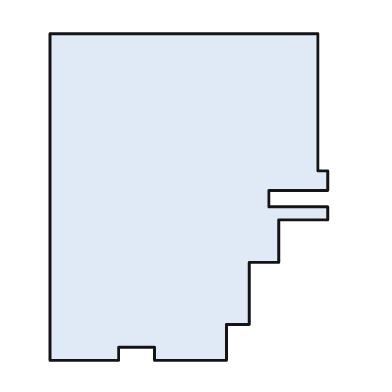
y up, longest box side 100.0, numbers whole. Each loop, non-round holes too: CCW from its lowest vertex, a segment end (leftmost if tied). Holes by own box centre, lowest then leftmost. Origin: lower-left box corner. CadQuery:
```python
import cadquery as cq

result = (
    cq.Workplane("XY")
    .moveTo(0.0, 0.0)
    .lineTo(21.0, 0.0)
    .lineTo(21.0, 4.0)
    .lineTo(32.0, 4.0)
    .lineTo(32.0, 0.0)
    .lineTo(54.0, 0.0)
    .lineTo(54.0, 11.0)
    .lineTo(61.0, 11.0)
    .lineTo(61.0, 30.0)
    .lineTo(70.0, 30.0)
    .lineTo(70.0, 43.0)
    .lineTo(85.0, 43.0)
    .lineTo(85.0, 47.0)
    .lineTo(67.0, 47.0)
    .lineTo(67.0, 52.0)
    .lineTo(85.0, 52.0)
    .lineTo(85.0, 58.0)
    .lineTo(82.0, 58.0)
    .lineTo(82.0, 100.0)
    .lineTo(0.0, 100.0)
    .close()
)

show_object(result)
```